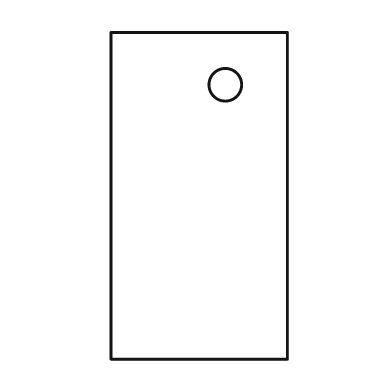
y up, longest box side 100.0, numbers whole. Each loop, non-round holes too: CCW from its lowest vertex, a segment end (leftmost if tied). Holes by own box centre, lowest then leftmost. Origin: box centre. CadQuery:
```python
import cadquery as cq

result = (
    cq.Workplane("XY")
    .moveTo(-27.0, -50.0)
    .lineTo(27.0, -50.0)
    .lineTo(27.0, 50.0)
    .lineTo(-27.0, 50.0)
    .close()
    .moveTo(8.0, 34.0)
    .circle(5.0)
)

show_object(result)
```